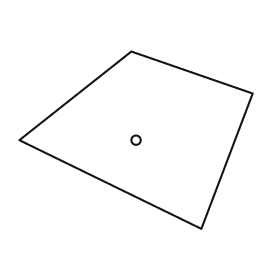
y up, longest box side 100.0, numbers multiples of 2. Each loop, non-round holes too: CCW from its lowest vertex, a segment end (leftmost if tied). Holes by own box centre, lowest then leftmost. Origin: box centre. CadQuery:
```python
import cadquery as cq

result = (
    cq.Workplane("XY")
    .moveTo(28.0, -38.0)
    .lineTo(50.0, 20.0)
    .lineTo(-2.0, 38.0)
    .lineTo(-50.0, 0.0)
    .close()
    .moveTo(0.0, 0.0)
    .circle(2.0)
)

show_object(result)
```